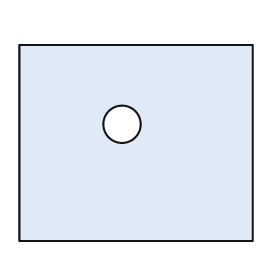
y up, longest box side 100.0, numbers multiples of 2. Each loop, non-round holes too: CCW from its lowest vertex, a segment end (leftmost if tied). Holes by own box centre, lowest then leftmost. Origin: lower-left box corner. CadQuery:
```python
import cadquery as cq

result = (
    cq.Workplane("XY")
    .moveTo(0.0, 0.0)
    .lineTo(100.0, 0.0)
    .lineTo(100.0, 84.0)
    .lineTo(0.0, 84.0)
    .close()
    .moveTo(44.0, 50.0)
    .circle(8.0)
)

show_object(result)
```